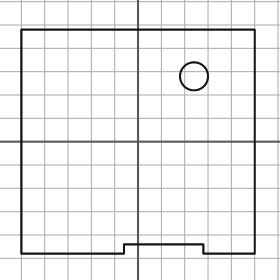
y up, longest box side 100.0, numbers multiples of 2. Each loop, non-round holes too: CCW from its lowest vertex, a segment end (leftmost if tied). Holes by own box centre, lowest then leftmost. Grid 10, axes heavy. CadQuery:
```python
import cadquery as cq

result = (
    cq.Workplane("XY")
    .moveTo(-50.0, -48.0)
    .lineTo(-6.0, -48.0)
    .lineTo(-6.0, -44.0)
    .lineTo(28.0, -44.0)
    .lineTo(28.0, -48.0)
    .lineTo(50.0, -48.0)
    .lineTo(50.0, 48.0)
    .lineTo(-50.0, 48.0)
    .close()
    .moveTo(24.0, 28.0)
    .circle(6.0)
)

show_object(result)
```